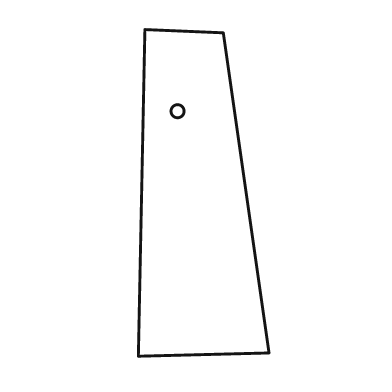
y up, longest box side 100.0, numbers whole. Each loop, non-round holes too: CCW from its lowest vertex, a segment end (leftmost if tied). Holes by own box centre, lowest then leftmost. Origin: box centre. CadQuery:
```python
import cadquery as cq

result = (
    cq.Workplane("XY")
    .moveTo(-20.0, -50.0)
    .lineTo(20.0, -49.0)
    .lineTo(6.0, 49.0)
    .lineTo(-18.0, 50.0)
    .close()
    .moveTo(-8.0, 25.0)
    .circle(2.0)
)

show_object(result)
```